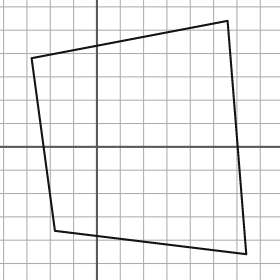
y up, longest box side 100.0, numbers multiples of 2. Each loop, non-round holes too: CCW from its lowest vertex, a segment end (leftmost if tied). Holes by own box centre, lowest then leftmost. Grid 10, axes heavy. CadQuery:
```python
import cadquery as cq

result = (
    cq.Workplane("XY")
    .moveTo(64.0, -46.0)
    .lineTo(56.0, 54.0)
    .lineTo(-28.0, 38.0)
    .lineTo(-18.0, -36.0)
    .close()
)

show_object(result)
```